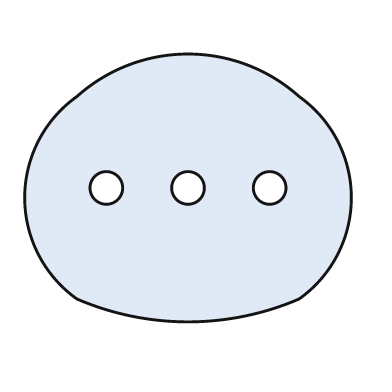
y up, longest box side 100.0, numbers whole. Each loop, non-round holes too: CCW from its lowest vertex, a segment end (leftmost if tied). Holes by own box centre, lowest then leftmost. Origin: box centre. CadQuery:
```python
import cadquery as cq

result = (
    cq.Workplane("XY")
    .moveTo(-34.0, -34.0)
    .threePointArc((0.0, -41.0), (34.0, -34.0))
    .threePointArc((50.0, -3.0), (34.0, 28.0))
    .threePointArc((0.0, 41.0), (-34.0, 28.0))
    .threePointArc((-50.0, -3.0), (-34.0, -34.0))
    .close()
    .moveTo(-25.0, 0.0)
    .circle(5.0)
    .moveTo(0.0, 0.0)
    .circle(5.0)
    .moveTo(25.0, 0.0)
    .circle(5.0)
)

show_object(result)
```